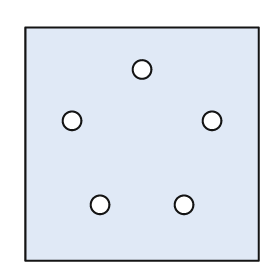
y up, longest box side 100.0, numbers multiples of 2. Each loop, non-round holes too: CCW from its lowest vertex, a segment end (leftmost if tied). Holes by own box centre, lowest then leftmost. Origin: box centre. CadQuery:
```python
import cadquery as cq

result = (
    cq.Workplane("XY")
    .moveTo(-50.0, -50.0)
    .lineTo(50.0, -50.0)
    .lineTo(50.0, 50.0)
    .lineTo(-50.0, 50.0)
    .close()
    .moveTo(-18.0, -26.0)
    .circle(4.0)
    .moveTo(18.0, -26.0)
    .circle(4.0)
    .moveTo(-30.0, 10.0)
    .circle(4.0)
    .moveTo(30.0, 10.0)
    .circle(4.0)
    .moveTo(0.0, 32.0)
    .circle(4.0)
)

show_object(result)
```